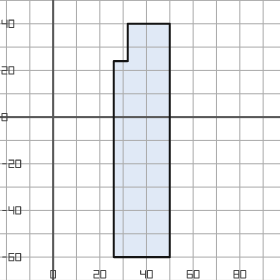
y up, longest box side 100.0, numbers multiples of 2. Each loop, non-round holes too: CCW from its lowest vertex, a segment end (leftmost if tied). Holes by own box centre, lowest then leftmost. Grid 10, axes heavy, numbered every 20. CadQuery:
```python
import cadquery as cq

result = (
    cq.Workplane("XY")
    .moveTo(26.0, -60.0)
    .lineTo(50.0, -60.0)
    .lineTo(50.0, 40.0)
    .lineTo(32.0, 40.0)
    .lineTo(32.0, 24.0)
    .lineTo(26.0, 24.0)
    .close()
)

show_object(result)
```